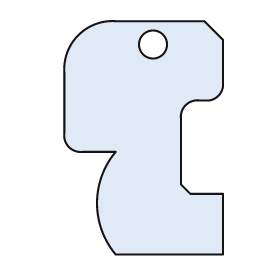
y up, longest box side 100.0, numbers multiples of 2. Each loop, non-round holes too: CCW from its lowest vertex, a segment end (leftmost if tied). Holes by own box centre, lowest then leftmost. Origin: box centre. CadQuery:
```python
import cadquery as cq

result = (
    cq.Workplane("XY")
    .moveTo(-12.0, -50.0)
    .lineTo(34.0, -50.0)
    .lineTo(34.0, -24.0)
    .lineTo(20.0, -24.0)
    .lineTo(16.0, -20.0)
    .lineTo(16.0, 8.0)
    .threePointArc((18.0, 14.0), (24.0, 16.0))
    .lineTo(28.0, 16.0)
    .threePointArc((32.0, 18.0), (34.0, 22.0))
    .lineTo(34.0, 42.0)
    .lineTo(26.0, 50.0)
    .lineTo(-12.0, 50.0)
    .threePointArc((-28.0, 44.0), (-34.0, 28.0))
    .lineTo(-34.0, 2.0)
    .threePointArc((-32.0, -4.0), (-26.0, -6.0))
    .lineTo(-12.0, -6.0)
    .threePointArc((-20.0, -28.0), (-12.0, -50.0))
    .close()
    .moveTo(4.0, 40.0)
    .circle(6.0)
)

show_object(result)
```